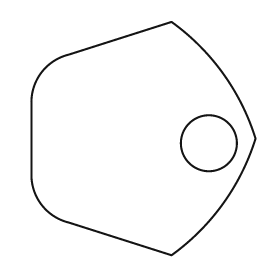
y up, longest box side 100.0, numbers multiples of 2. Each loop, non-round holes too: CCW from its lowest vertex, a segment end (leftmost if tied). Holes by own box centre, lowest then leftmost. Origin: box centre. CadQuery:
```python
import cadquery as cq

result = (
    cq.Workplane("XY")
    .moveTo(12.0, -50.0)
    .threePointArc((34.0, -28.0), (48.0, 0.0))
    .threePointArc((34.0, 28.0), (12.0, 50.0))
    .lineTo(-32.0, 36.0)
    .threePointArc((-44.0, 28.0), (-48.0, 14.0))
    .lineTo(-48.0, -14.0)
    .threePointArc((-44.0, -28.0), (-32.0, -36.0))
    .close()
    .moveTo(28.0, -2.0)
    .circle(12.0)
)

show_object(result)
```